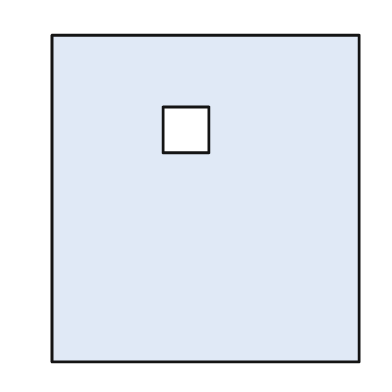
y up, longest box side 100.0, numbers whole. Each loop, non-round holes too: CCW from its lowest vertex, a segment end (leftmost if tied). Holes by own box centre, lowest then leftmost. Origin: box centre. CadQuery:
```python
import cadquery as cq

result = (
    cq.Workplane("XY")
    .moveTo(-47.0, -50.0)
    .lineTo(47.0, -50.0)
    .lineTo(47.0, 50.0)
    .lineTo(-47.0, 50.0)
    .close()
    .moveTo(-13.0, 14.0)
    .lineTo(1.0, 14.0)
    .lineTo(1.0, 28.0)
    .lineTo(-13.0, 28.0)
    .close()
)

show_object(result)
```